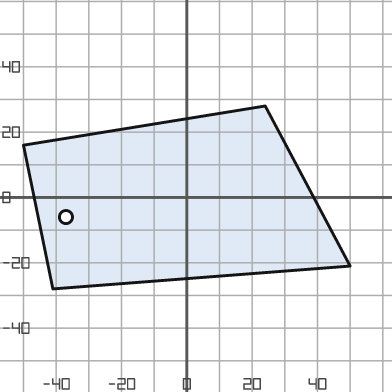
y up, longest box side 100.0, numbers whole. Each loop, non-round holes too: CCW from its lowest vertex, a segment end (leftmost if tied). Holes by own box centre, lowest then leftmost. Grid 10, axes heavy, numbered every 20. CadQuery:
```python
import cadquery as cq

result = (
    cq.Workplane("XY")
    .moveTo(-41.0, -28.0)
    .lineTo(50.0, -21.0)
    .lineTo(24.0, 28.0)
    .lineTo(-50.0, 16.0)
    .close()
    .moveTo(-37.0, -6.0)
    .circle(2.0)
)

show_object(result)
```